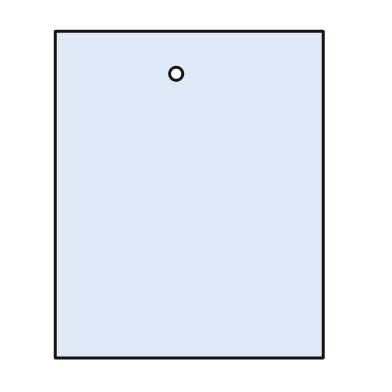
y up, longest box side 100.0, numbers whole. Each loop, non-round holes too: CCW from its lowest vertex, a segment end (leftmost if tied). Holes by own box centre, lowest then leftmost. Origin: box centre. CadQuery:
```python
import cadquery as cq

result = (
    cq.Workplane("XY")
    .moveTo(-41.0, -50.0)
    .lineTo(41.0, -50.0)
    .lineTo(41.0, 50.0)
    .lineTo(-41.0, 50.0)
    .close()
    .moveTo(-4.0, 37.0)
    .circle(2.0)
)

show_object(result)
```